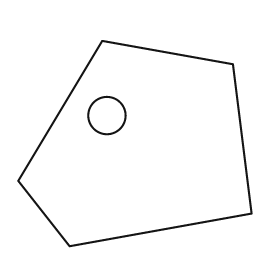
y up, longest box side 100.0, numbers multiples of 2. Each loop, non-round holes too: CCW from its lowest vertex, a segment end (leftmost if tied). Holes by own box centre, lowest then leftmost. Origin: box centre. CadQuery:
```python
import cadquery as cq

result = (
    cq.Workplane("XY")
    .moveTo(-28.0, -44.0)
    .lineTo(50.0, -30.0)
    .lineTo(42.0, 34.0)
    .lineTo(-14.0, 44.0)
    .lineTo(-50.0, -16.0)
    .close()
    .moveTo(-12.0, 12.0)
    .circle(8.0)
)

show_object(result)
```